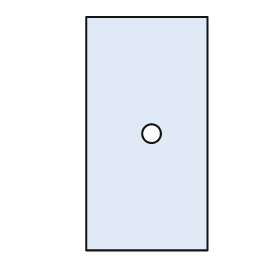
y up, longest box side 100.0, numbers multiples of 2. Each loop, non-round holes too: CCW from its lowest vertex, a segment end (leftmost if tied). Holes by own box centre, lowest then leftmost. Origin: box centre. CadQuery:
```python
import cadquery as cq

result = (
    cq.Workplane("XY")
    .moveTo(-26.0, -50.0)
    .lineTo(26.0, -50.0)
    .lineTo(26.0, 50.0)
    .lineTo(-26.0, 50.0)
    .close()
    .moveTo(2.0, 0.0)
    .circle(4.0)
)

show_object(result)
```